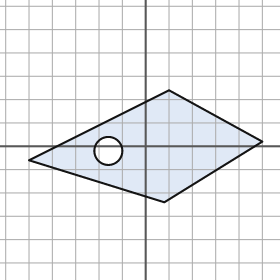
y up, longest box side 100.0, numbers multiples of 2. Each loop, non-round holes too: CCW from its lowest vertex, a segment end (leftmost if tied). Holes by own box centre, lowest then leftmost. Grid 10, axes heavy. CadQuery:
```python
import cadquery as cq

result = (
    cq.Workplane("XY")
    .moveTo(8.0, -24.0)
    .lineTo(50.0, 2.0)
    .lineTo(10.0, 24.0)
    .lineTo(-50.0, -6.0)
    .close()
    .moveTo(-16.0, -2.0)
    .circle(6.0)
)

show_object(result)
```